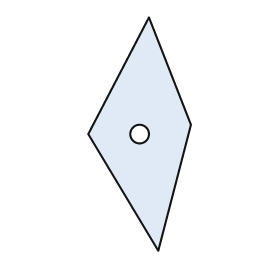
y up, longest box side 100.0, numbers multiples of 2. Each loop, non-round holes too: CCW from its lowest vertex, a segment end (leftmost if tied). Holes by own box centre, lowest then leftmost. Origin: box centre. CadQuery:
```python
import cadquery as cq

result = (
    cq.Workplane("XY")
    .moveTo(8.0, -50.0)
    .lineTo(22.0, 4.0)
    .lineTo(4.0, 50.0)
    .lineTo(-22.0, 0.0)
    .close()
    .moveTo(0.0, 0.0)
    .circle(4.0)
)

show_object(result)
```